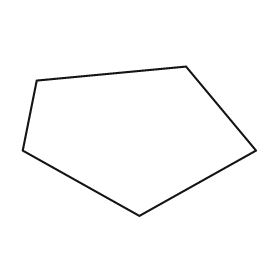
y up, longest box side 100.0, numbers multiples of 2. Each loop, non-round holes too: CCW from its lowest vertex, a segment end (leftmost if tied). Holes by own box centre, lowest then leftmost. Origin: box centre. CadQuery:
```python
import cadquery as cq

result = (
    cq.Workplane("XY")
    .moveTo(0.0, -32.0)
    .lineTo(50.0, -4.0)
    .lineTo(20.0, 32.0)
    .lineTo(-44.0, 26.0)
    .lineTo(-50.0, -4.0)
    .close()
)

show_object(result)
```